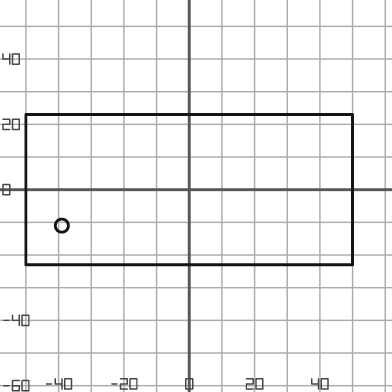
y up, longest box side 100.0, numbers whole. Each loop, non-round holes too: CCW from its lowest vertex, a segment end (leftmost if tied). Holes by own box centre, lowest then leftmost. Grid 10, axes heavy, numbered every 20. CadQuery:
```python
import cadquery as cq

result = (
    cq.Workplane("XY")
    .moveTo(-50.0, -23.0)
    .lineTo(50.0, -23.0)
    .lineTo(50.0, 23.0)
    .lineTo(-50.0, 23.0)
    .close()
    .moveTo(-39.0, -11.0)
    .circle(2.0)
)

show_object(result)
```